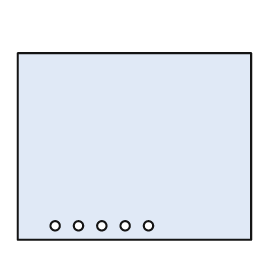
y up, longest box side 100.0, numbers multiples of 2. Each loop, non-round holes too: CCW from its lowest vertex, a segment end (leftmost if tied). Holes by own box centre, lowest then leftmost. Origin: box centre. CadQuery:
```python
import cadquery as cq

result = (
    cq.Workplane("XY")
    .moveTo(-50.0, -40.0)
    .lineTo(50.0, -40.0)
    .lineTo(50.0, 40.0)
    .lineTo(-50.0, 40.0)
    .close()
    .moveTo(-34.0, -34.0)
    .circle(2.0)
    .moveTo(-24.0, -34.0)
    .circle(2.0)
    .moveTo(-14.0, -34.0)
    .circle(2.0)
    .moveTo(-4.0, -34.0)
    .circle(2.0)
    .moveTo(6.0, -34.0)
    .circle(2.0)
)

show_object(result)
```